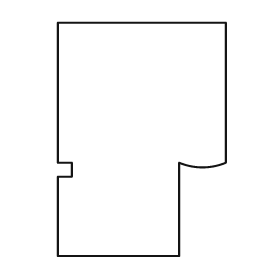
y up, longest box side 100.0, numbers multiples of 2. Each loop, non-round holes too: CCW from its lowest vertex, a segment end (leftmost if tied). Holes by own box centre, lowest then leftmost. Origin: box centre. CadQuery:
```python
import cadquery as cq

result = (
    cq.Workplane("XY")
    .moveTo(-36.0, -50.0)
    .lineTo(16.0, -50.0)
    .lineTo(16.0, -10.0)
    .threePointArc((26.0, -12.0), (36.0, -10.0))
    .lineTo(36.0, 50.0)
    .lineTo(-36.0, 50.0)
    .lineTo(-36.0, -10.0)
    .lineTo(-30.0, -10.0)
    .lineTo(-30.0, -16.0)
    .lineTo(-36.0, -16.0)
    .close()
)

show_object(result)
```